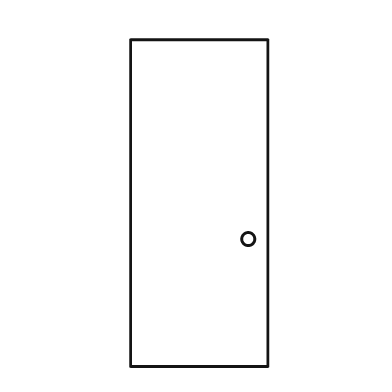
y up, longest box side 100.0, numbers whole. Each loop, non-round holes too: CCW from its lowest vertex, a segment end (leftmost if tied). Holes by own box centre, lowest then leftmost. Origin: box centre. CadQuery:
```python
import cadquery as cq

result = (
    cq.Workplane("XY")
    .moveTo(-21.0, -50.0)
    .lineTo(21.0, -50.0)
    .lineTo(21.0, 50.0)
    .lineTo(-21.0, 50.0)
    .close()
    .moveTo(15.0, -11.0)
    .circle(2.0)
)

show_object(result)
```